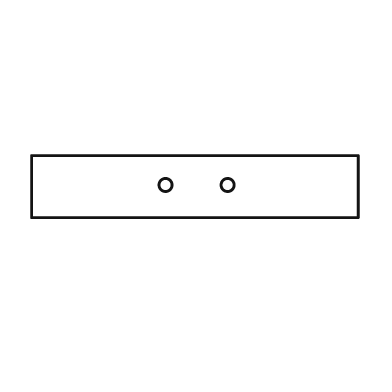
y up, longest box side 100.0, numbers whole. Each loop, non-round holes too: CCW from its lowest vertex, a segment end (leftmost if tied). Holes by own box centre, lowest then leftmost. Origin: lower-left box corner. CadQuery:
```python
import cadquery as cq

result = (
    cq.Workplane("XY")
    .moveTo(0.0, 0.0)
    .lineTo(100.0, 0.0)
    .lineTo(100.0, 19.0)
    .lineTo(0.0, 19.0)
    .close()
    .moveTo(41.0, 10.0)
    .circle(2.0)
    .moveTo(60.0, 10.0)
    .circle(2.0)
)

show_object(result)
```